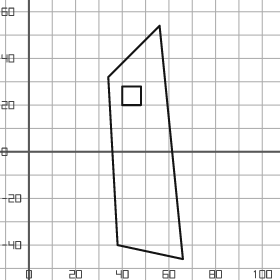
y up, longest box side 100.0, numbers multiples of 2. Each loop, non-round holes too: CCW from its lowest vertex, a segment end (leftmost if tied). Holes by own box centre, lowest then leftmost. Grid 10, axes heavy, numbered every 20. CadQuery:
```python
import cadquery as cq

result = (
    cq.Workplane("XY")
    .moveTo(66.0, -46.0)
    .lineTo(56.0, 54.0)
    .lineTo(34.0, 32.0)
    .lineTo(38.0, -40.0)
    .close()
    .moveTo(40.0, 20.0)
    .lineTo(48.0, 20.0)
    .lineTo(48.0, 28.0)
    .lineTo(40.0, 28.0)
    .close()
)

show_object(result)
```